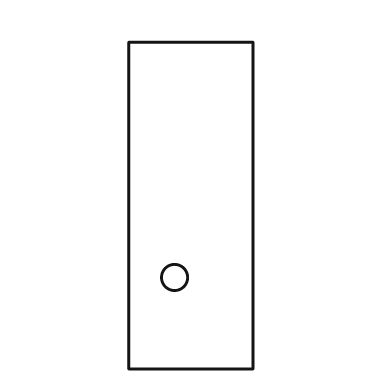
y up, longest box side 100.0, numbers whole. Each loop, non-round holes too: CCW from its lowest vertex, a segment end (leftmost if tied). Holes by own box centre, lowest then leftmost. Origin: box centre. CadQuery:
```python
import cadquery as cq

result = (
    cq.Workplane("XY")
    .moveTo(-19.0, -50.0)
    .lineTo(19.0, -50.0)
    .lineTo(19.0, 50.0)
    .lineTo(-19.0, 50.0)
    .close()
    .moveTo(-5.0, -22.0)
    .circle(4.0)
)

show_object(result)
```